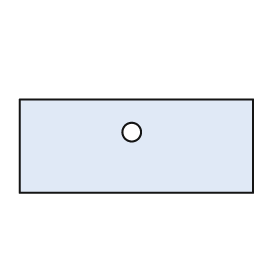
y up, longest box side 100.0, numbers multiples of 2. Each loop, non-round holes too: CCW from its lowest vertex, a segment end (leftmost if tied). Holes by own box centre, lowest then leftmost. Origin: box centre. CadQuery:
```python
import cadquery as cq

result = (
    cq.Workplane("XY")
    .moveTo(-50.0, -20.0)
    .lineTo(50.0, -20.0)
    .lineTo(50.0, 20.0)
    .lineTo(-50.0, 20.0)
    .close()
    .moveTo(-2.0, 6.0)
    .circle(4.0)
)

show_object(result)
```